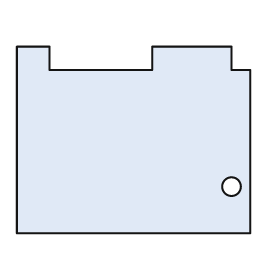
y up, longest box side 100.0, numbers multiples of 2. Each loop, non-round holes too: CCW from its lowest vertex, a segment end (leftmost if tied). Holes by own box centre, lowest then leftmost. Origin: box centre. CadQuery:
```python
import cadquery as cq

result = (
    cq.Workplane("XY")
    .moveTo(-50.0, -40.0)
    .lineTo(50.0, -40.0)
    .lineTo(50.0, 30.0)
    .lineTo(42.0, 30.0)
    .lineTo(42.0, 40.0)
    .lineTo(8.0, 40.0)
    .lineTo(8.0, 30.0)
    .lineTo(-36.0, 30.0)
    .lineTo(-36.0, 40.0)
    .lineTo(-50.0, 40.0)
    .close()
    .moveTo(42.0, -20.0)
    .circle(4.0)
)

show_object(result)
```